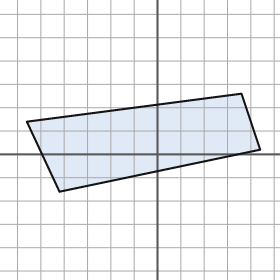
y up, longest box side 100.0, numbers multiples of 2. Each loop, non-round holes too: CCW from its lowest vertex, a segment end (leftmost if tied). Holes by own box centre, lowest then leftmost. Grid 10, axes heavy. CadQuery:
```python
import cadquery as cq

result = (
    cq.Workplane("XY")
    .moveTo(-42.0, -16.0)
    .lineTo(44.0, 2.0)
    .lineTo(36.0, 26.0)
    .lineTo(-56.0, 14.0)
    .close()
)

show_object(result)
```